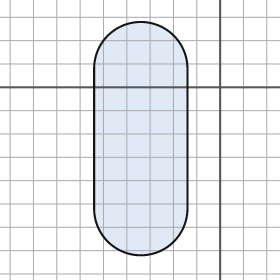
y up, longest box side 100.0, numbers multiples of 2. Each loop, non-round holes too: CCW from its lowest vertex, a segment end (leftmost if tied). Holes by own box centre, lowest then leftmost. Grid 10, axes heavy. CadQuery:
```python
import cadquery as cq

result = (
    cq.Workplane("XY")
    .moveTo(-54.0, -52.0)
    .threePointArc((-34.0, -72.0), (-14.0, -52.0))
    .lineTo(-14.0, 8.0)
    .threePointArc((-34.0, 28.0), (-54.0, 8.0))
    .close()
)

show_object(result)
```